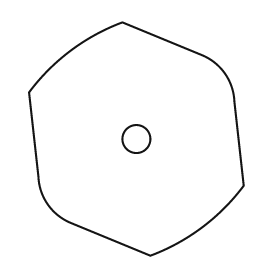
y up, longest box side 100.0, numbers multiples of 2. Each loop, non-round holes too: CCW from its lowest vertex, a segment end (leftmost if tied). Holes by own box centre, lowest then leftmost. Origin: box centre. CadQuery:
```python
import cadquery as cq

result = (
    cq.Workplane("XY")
    .moveTo(6.0, -50.0)
    .threePointArc((28.0, -38.0), (46.0, -20.0))
    .lineTo(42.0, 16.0)
    .threePointArc((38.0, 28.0), (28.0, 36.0))
    .lineTo(-6.0, 50.0)
    .threePointArc((-28.0, 38.0), (-46.0, 20.0))
    .lineTo(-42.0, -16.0)
    .threePointArc((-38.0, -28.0), (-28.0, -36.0))
    .close()
    .moveTo(0.0, 0.0)
    .circle(6.0)
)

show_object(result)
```